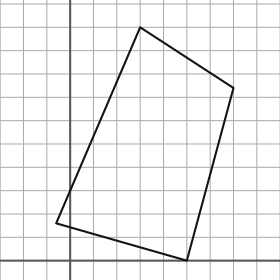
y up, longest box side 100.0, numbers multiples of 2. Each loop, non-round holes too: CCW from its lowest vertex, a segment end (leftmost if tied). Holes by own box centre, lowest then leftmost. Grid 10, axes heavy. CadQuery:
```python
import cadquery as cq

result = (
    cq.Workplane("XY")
    .moveTo(50.0, 0.0)
    .lineTo(70.0, 74.0)
    .lineTo(30.0, 100.0)
    .lineTo(-6.0, 16.0)
    .close()
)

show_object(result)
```